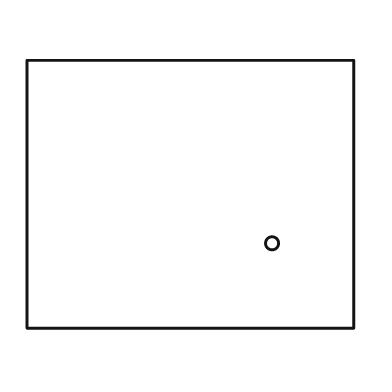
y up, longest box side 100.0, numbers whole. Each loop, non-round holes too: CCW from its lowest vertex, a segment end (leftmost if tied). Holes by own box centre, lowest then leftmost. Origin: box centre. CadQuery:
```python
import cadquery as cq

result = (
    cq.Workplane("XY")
    .moveTo(-50.0, -41.0)
    .lineTo(50.0, -41.0)
    .lineTo(50.0, 41.0)
    .lineTo(-50.0, 41.0)
    .close()
    .moveTo(25.0, -15.0)
    .circle(2.0)
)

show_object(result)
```